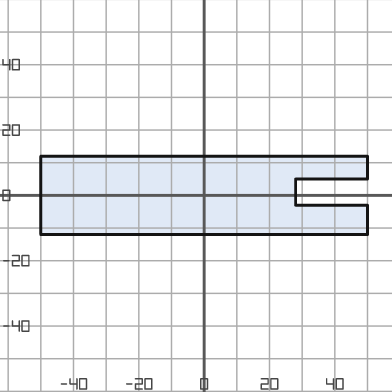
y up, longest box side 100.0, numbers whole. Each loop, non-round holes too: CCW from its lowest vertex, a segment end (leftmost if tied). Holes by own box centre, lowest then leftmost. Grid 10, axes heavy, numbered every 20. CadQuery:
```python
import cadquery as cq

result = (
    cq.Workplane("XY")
    .moveTo(-50.0, -12.0)
    .lineTo(50.0, -12.0)
    .lineTo(50.0, -3.0)
    .lineTo(28.0, -3.0)
    .lineTo(28.0, 5.0)
    .lineTo(50.0, 5.0)
    .lineTo(50.0, 12.0)
    .lineTo(-50.0, 12.0)
    .close()
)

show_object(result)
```